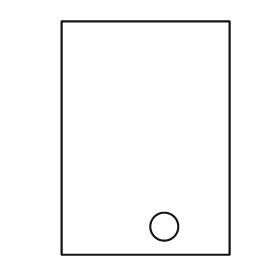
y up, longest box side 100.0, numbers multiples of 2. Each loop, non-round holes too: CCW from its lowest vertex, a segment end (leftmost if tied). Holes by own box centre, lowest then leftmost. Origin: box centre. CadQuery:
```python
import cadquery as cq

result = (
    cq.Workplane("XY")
    .moveTo(-36.0, -50.0)
    .lineTo(36.0, -50.0)
    .lineTo(36.0, 50.0)
    .lineTo(-36.0, 50.0)
    .close()
    .moveTo(8.0, -38.0)
    .circle(6.0)
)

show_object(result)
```